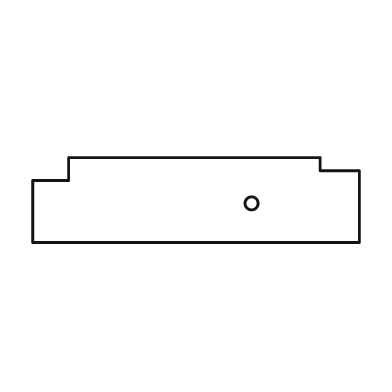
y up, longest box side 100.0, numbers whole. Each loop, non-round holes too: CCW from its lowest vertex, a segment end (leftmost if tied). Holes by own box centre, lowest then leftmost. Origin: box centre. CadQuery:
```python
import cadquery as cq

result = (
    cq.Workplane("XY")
    .moveTo(-50.0, -13.0)
    .lineTo(50.0, -13.0)
    .lineTo(50.0, 9.0)
    .lineTo(38.0, 9.0)
    .lineTo(38.0, 13.0)
    .lineTo(-39.0, 13.0)
    .lineTo(-39.0, 6.0)
    .lineTo(-50.0, 6.0)
    .close()
    .moveTo(17.0, -1.0)
    .circle(2.0)
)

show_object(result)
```